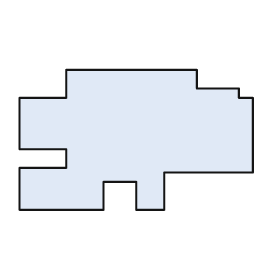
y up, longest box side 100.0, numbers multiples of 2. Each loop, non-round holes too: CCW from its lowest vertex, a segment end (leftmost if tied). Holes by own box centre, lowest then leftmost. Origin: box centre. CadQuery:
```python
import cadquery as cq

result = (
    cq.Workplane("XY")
    .moveTo(-50.0, -30.0)
    .lineTo(-14.0, -30.0)
    .lineTo(-14.0, -18.0)
    .lineTo(0.0, -18.0)
    .lineTo(0.0, -30.0)
    .lineTo(12.0, -30.0)
    .lineTo(12.0, -14.0)
    .lineTo(50.0, -14.0)
    .lineTo(50.0, 18.0)
    .lineTo(44.0, 18.0)
    .lineTo(44.0, 22.0)
    .lineTo(26.0, 22.0)
    .lineTo(26.0, 30.0)
    .lineTo(-30.0, 30.0)
    .lineTo(-30.0, 18.0)
    .lineTo(-50.0, 18.0)
    .lineTo(-50.0, -4.0)
    .lineTo(-30.0, -4.0)
    .lineTo(-30.0, -12.0)
    .lineTo(-50.0, -12.0)
    .close()
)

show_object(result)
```